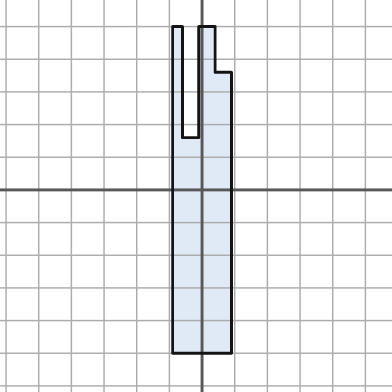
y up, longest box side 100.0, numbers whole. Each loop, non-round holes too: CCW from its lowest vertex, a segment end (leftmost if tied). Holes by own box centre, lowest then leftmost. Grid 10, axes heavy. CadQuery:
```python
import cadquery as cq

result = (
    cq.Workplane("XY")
    .moveTo(-9.0, -50.0)
    .lineTo(9.0, -50.0)
    .lineTo(9.0, 36.0)
    .lineTo(4.0, 36.0)
    .lineTo(4.0, 50.0)
    .lineTo(-1.0, 50.0)
    .lineTo(-1.0, 16.0)
    .lineTo(-6.0, 16.0)
    .lineTo(-6.0, 50.0)
    .lineTo(-9.0, 50.0)
    .close()
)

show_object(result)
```